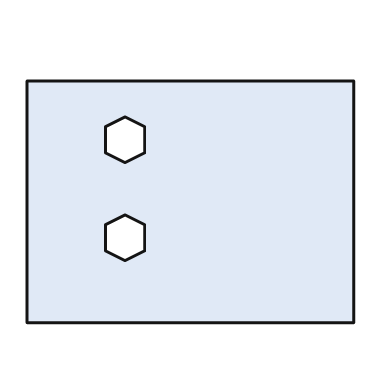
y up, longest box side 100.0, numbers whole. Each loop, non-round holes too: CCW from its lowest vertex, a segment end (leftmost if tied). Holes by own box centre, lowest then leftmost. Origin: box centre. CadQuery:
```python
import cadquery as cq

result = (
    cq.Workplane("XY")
    .moveTo(-50.0, -37.0)
    .lineTo(50.0, -37.0)
    .lineTo(50.0, 37.0)
    .lineTo(-50.0, 37.0)
    .close()
    .moveTo(-20.0, -18.0)
    .lineTo(-14.0, -15.0)
    .lineTo(-14.0, -7.0)
    .lineTo(-20.0, -4.0)
    .lineTo(-26.0, -7.0)
    .lineTo(-26.0, -15.0)
    .close()
    .moveTo(-20.0, 12.0)
    .lineTo(-14.0, 15.0)
    .lineTo(-14.0, 23.0)
    .lineTo(-20.0, 26.0)
    .lineTo(-26.0, 23.0)
    .lineTo(-26.0, 15.0)
    .close()
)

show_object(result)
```